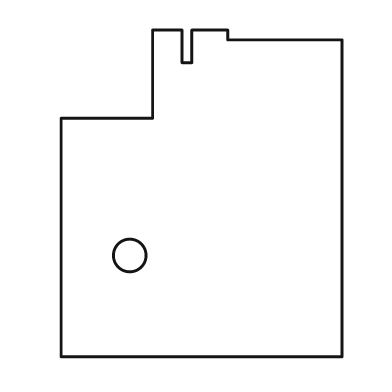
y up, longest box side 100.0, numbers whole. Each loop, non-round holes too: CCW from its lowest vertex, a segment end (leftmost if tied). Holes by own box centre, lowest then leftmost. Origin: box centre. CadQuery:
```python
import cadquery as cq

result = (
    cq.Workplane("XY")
    .moveTo(-43.0, -50.0)
    .lineTo(43.0, -50.0)
    .lineTo(43.0, 47.0)
    .lineTo(8.0, 47.0)
    .lineTo(8.0, 50.0)
    .lineTo(-3.0, 50.0)
    .lineTo(-3.0, 40.0)
    .lineTo(-6.0, 40.0)
    .lineTo(-6.0, 50.0)
    .lineTo(-15.0, 50.0)
    .lineTo(-15.0, 23.0)
    .lineTo(-43.0, 23.0)
    .close()
    .moveTo(-22.0, -19.0)
    .circle(5.0)
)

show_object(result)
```